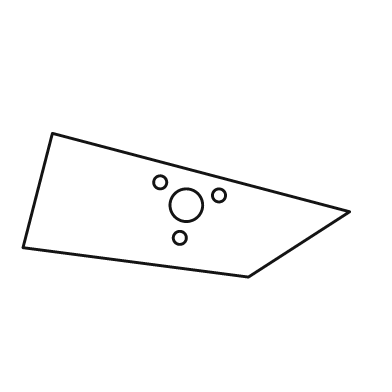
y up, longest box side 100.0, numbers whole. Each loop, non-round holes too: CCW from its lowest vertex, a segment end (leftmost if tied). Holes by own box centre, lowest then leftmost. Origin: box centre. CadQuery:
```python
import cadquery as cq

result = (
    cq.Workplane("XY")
    .moveTo(19.0, -22.0)
    .lineTo(50.0, -2.0)
    .lineTo(-41.0, 22.0)
    .lineTo(-50.0, -13.0)
    .close()
    .moveTo(-2.0, -10.0)
    .circle(2.0)
    .moveTo(0.0, 0.0)
    .circle(5.0)
    .moveTo(10.0, 3.0)
    .circle(2.0)
    .moveTo(-8.0, 7.0)
    .circle(2.0)
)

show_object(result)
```